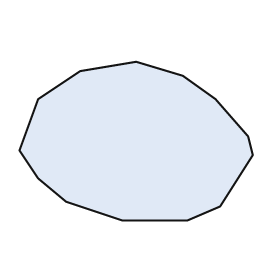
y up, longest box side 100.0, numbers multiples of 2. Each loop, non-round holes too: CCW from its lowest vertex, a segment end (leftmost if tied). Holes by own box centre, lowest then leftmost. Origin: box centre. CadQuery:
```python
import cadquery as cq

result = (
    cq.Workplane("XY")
    .moveTo(-6.0, -34.0)
    .lineTo(22.0, -34.0)
    .lineTo(36.0, -28.0)
    .lineTo(50.0, -6.0)
    .lineTo(48.0, 2.0)
    .lineTo(34.0, 18.0)
    .lineTo(20.0, 28.0)
    .lineTo(0.0, 34.0)
    .lineTo(-24.0, 30.0)
    .lineTo(-42.0, 18.0)
    .lineTo(-50.0, -4.0)
    .lineTo(-42.0, -16.0)
    .lineTo(-30.0, -26.0)
    .close()
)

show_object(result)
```